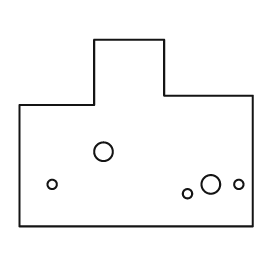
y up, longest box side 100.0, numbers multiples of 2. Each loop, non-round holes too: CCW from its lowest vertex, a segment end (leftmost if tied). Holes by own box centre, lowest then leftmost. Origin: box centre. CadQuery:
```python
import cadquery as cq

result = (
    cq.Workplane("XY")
    .moveTo(-50.0, -40.0)
    .lineTo(50.0, -40.0)
    .lineTo(50.0, 16.0)
    .lineTo(12.0, 16.0)
    .lineTo(12.0, 40.0)
    .lineTo(-18.0, 40.0)
    .lineTo(-18.0, 12.0)
    .lineTo(-50.0, 12.0)
    .close()
    .moveTo(22.0, -26.0)
    .circle(2.0)
    .moveTo(-36.0, -22.0)
    .circle(2.0)
    .moveTo(32.0, -22.0)
    .circle(4.0)
    .moveTo(44.0, -22.0)
    .circle(2.0)
    .moveTo(-14.0, -8.0)
    .circle(4.0)
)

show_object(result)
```